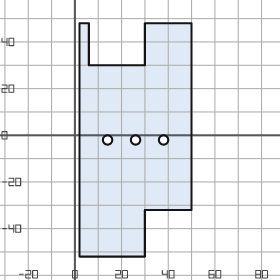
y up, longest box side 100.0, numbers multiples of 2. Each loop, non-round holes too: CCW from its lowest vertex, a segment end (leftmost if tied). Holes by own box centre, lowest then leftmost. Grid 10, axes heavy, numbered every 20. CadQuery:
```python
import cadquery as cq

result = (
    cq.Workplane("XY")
    .moveTo(2.0, -52.0)
    .lineTo(30.0, -52.0)
    .lineTo(30.0, -32.0)
    .lineTo(50.0, -32.0)
    .lineTo(50.0, 48.0)
    .lineTo(30.0, 48.0)
    .lineTo(30.0, 30.0)
    .lineTo(6.0, 30.0)
    .lineTo(6.0, 48.0)
    .lineTo(2.0, 48.0)
    .close()
    .moveTo(14.0, -2.0)
    .circle(2.0)
    .moveTo(26.0, -2.0)
    .circle(2.0)
    .moveTo(38.0, -2.0)
    .circle(2.0)
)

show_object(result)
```